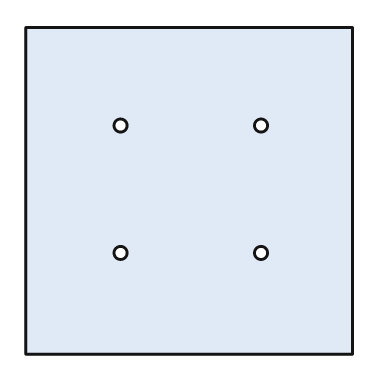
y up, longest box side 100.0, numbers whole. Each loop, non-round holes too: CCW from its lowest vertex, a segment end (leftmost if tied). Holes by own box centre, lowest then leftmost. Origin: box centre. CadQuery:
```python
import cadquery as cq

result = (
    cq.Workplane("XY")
    .moveTo(-50.0, -50.0)
    .lineTo(50.0, -50.0)
    .lineTo(50.0, 50.0)
    .lineTo(-50.0, 50.0)
    .close()
    .moveTo(-21.0, -19.0)
    .circle(2.0)
    .moveTo(22.0, -19.0)
    .circle(2.0)
    .moveTo(-21.0, 20.0)
    .circle(2.0)
    .moveTo(22.0, 20.0)
    .circle(2.0)
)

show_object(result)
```